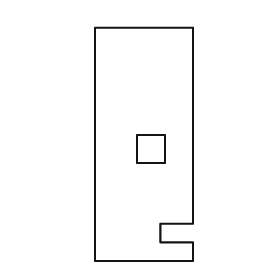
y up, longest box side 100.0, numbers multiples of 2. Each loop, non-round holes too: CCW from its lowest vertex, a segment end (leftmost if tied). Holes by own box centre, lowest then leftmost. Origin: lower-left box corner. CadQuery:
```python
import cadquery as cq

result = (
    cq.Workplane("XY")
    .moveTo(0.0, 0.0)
    .lineTo(42.0, 0.0)
    .lineTo(42.0, 8.0)
    .lineTo(28.0, 8.0)
    .lineTo(28.0, 16.0)
    .lineTo(42.0, 16.0)
    .lineTo(42.0, 100.0)
    .lineTo(0.0, 100.0)
    .close()
    .moveTo(18.0, 42.0)
    .lineTo(30.0, 42.0)
    .lineTo(30.0, 54.0)
    .lineTo(18.0, 54.0)
    .close()
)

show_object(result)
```